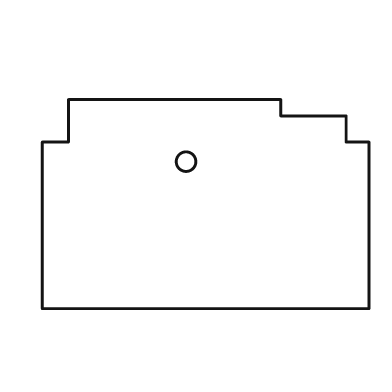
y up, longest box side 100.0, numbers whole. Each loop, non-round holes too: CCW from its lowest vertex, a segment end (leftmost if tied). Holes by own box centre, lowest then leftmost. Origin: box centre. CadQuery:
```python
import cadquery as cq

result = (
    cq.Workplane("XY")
    .moveTo(-50.0, -32.0)
    .lineTo(50.0, -32.0)
    .lineTo(50.0, 19.0)
    .lineTo(43.0, 19.0)
    .lineTo(43.0, 27.0)
    .lineTo(23.0, 27.0)
    .lineTo(23.0, 32.0)
    .lineTo(-42.0, 32.0)
    .lineTo(-42.0, 19.0)
    .lineTo(-50.0, 19.0)
    .close()
    .moveTo(-6.0, 13.0)
    .circle(3.0)
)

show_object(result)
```